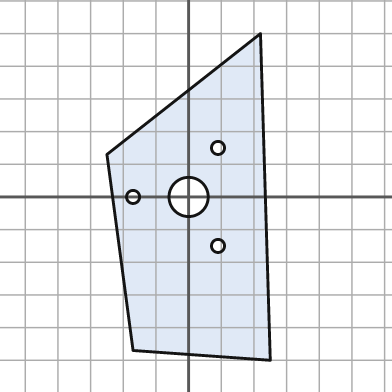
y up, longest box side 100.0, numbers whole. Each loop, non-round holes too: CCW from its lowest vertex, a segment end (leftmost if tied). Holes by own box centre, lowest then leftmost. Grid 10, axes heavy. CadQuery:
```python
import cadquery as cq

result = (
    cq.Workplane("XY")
    .moveTo(25.0, -50.0)
    .lineTo(22.0, 50.0)
    .lineTo(-25.0, 13.0)
    .lineTo(-17.0, -47.0)
    .close()
    .moveTo(9.0, -15.0)
    .circle(2.0)
    .moveTo(-17.0, 0.0)
    .circle(2.0)
    .moveTo(0.0, 0.0)
    .circle(6.0)
    .moveTo(9.0, 15.0)
    .circle(2.0)
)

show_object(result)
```